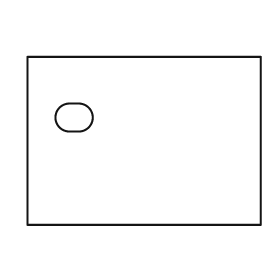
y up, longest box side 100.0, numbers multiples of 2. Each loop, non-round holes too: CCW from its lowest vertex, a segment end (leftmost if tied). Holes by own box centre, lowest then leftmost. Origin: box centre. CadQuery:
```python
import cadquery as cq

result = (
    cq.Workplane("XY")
    .moveTo(-50.0, -36.0)
    .lineTo(50.0, -36.0)
    .lineTo(50.0, 36.0)
    .lineTo(-50.0, 36.0)
    .close()
    .moveTo(-32.0, 4.0)
    .lineTo(-28.0, 4.0)
    .threePointArc((-22.0, 10.0), (-28.0, 16.0))
    .lineTo(-32.0, 16.0)
    .threePointArc((-38.0, 10.0), (-32.0, 4.0))
    .close()
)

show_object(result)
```